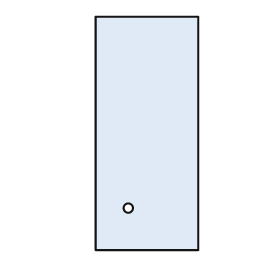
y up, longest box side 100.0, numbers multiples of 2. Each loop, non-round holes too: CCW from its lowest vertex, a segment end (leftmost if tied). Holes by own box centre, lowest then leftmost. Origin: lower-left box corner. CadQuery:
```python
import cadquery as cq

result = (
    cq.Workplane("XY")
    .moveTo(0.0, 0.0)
    .lineTo(44.0, 0.0)
    .lineTo(44.0, 100.0)
    .lineTo(0.0, 100.0)
    .close()
    .moveTo(14.0, 18.0)
    .circle(2.0)
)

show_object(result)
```